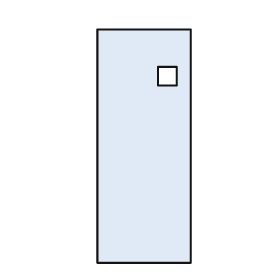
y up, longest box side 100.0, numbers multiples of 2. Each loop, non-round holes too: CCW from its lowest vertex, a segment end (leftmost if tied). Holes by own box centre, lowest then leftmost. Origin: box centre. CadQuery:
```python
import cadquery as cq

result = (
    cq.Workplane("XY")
    .moveTo(-20.0, -50.0)
    .lineTo(20.0, -50.0)
    .lineTo(20.0, 50.0)
    .lineTo(-20.0, 50.0)
    .close()
    .moveTo(6.0, 26.0)
    .lineTo(14.0, 26.0)
    .lineTo(14.0, 34.0)
    .lineTo(6.0, 34.0)
    .close()
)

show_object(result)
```